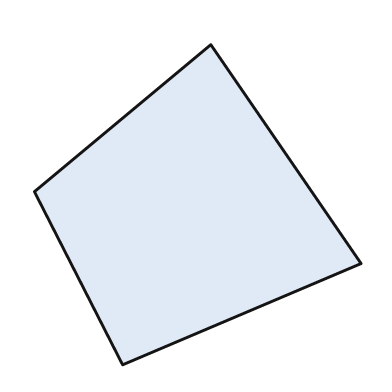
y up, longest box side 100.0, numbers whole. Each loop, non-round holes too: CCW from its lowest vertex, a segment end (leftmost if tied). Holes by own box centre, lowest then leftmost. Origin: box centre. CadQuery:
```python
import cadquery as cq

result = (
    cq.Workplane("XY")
    .moveTo(-23.0, -49.0)
    .lineTo(50.0, -18.0)
    .lineTo(4.0, 49.0)
    .lineTo(-50.0, 4.0)
    .close()
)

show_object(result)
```